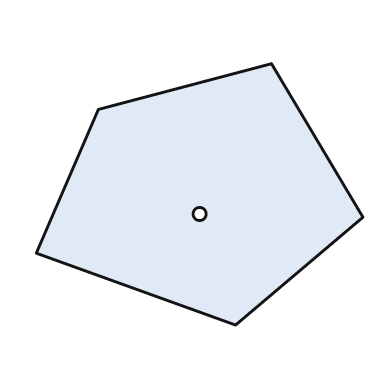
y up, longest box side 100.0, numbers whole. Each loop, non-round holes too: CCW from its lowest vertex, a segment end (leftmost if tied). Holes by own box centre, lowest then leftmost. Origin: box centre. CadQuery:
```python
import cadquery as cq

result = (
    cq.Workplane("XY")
    .moveTo(11.0, -40.0)
    .lineTo(50.0, -7.0)
    .lineTo(22.0, 40.0)
    .lineTo(-31.0, 26.0)
    .lineTo(-50.0, -18.0)
    .close()
    .moveTo(0.0, -6.0)
    .circle(2.0)
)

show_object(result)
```